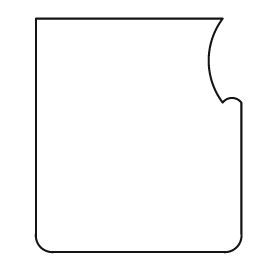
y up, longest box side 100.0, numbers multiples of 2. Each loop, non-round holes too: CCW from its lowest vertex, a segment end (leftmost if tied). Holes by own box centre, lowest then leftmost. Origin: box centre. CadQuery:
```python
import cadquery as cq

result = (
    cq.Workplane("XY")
    .moveTo(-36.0, -50.0)
    .lineTo(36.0, -50.0)
    .threePointArc((42.0, -48.0), (44.0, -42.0))
    .lineTo(44.0, 14.0)
    .threePointArc((40.0, 16.0), (36.0, 14.0))
    .threePointArc((30.0, 32.0), (36.0, 50.0))
    .lineTo(-44.0, 50.0)
    .lineTo(-44.0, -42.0)
    .threePointArc((-42.0, -48.0), (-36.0, -50.0))
    .close()
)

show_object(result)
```